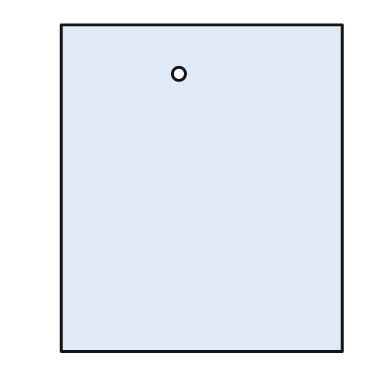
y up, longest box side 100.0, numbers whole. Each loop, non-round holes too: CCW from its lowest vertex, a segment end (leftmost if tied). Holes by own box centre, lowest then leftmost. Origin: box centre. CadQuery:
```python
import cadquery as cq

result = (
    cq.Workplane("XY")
    .moveTo(-43.0, -50.0)
    .lineTo(43.0, -50.0)
    .lineTo(43.0, 50.0)
    .lineTo(-43.0, 50.0)
    .close()
    .moveTo(-7.0, 35.0)
    .circle(2.0)
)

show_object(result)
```